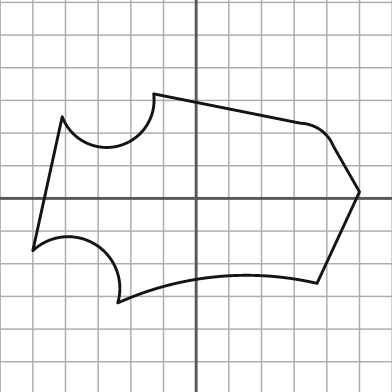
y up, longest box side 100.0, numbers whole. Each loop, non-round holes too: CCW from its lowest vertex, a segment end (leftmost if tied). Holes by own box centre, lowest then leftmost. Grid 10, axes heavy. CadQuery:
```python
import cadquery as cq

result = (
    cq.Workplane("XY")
    .moveTo(-24.0, -32.0)
    .threePointArc((6.0, -24.0), (37.0, -26.0))
    .lineTo(50.0, 2.0)
    .lineTo(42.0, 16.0)
    .threePointArc((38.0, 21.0), (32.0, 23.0))
    .lineTo(-13.0, 32.0)
    .threePointArc((-24.0, 16.0), (-41.0, 25.0))
    .lineTo(-50.0, -16.0)
    .threePointArc((-31.0, -14.0), (-24.0, -32.0))
    .close()
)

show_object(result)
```